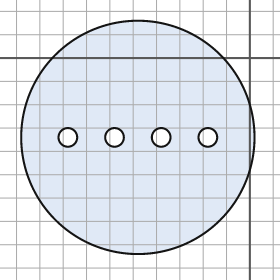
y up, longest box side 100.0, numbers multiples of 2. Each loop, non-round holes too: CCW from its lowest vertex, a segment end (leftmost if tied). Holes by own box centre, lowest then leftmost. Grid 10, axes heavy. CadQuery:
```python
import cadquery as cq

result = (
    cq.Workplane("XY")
    .moveTo(-48.0, -34.0)
    .circle(50.0)
    .moveTo(-78.0, -34.0)
    .circle(4.0)
    .moveTo(-58.0, -34.0)
    .circle(4.0)
    .moveTo(-38.0, -34.0)
    .circle(4.0)
    .moveTo(-18.0, -34.0)
    .circle(4.0)
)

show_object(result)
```